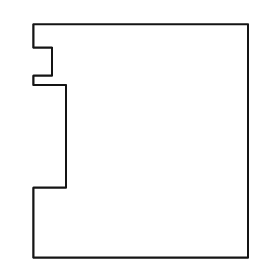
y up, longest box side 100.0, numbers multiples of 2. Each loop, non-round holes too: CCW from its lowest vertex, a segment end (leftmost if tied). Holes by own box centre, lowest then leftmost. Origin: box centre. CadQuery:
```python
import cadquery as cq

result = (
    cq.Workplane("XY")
    .moveTo(-46.0, -50.0)
    .lineTo(46.0, -50.0)
    .lineTo(46.0, 50.0)
    .lineTo(-46.0, 50.0)
    .lineTo(-46.0, 40.0)
    .lineTo(-38.0, 40.0)
    .lineTo(-38.0, 28.0)
    .lineTo(-46.0, 28.0)
    .lineTo(-46.0, 24.0)
    .lineTo(-32.0, 24.0)
    .lineTo(-32.0, -20.0)
    .lineTo(-46.0, -20.0)
    .close()
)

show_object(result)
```